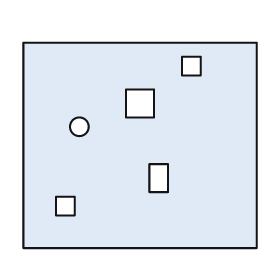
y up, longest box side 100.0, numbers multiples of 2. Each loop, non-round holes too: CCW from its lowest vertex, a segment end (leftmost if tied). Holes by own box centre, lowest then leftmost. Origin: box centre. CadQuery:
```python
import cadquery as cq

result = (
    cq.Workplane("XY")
    .moveTo(-50.0, -44.0)
    .lineTo(50.0, -44.0)
    .lineTo(50.0, 44.0)
    .lineTo(-50.0, 44.0)
    .close()
    .moveTo(-36.0, -30.0)
    .lineTo(-28.0, -30.0)
    .lineTo(-28.0, -22.0)
    .lineTo(-36.0, -22.0)
    .close()
    .moveTo(4.0, -20.0)
    .lineTo(12.0, -20.0)
    .lineTo(12.0, -8.0)
    .lineTo(4.0, -8.0)
    .close()
    .moveTo(-26.0, 8.0)
    .circle(4.0)
    .moveTo(-6.0, 12.0)
    .lineTo(6.0, 12.0)
    .lineTo(6.0, 24.0)
    .lineTo(-6.0, 24.0)
    .close()
    .moveTo(18.0, 30.0)
    .lineTo(26.0, 30.0)
    .lineTo(26.0, 38.0)
    .lineTo(18.0, 38.0)
    .close()
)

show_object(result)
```